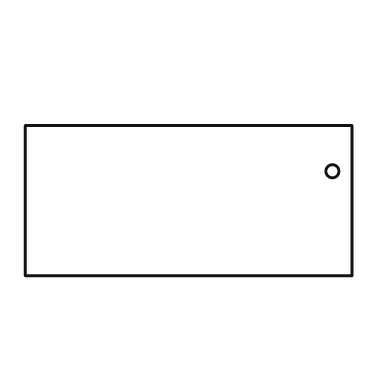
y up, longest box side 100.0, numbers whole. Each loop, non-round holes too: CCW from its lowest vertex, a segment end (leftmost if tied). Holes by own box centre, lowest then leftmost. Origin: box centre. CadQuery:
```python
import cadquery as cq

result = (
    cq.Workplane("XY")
    .moveTo(-50.0, -23.0)
    .lineTo(50.0, -23.0)
    .lineTo(50.0, 23.0)
    .lineTo(-50.0, 23.0)
    .close()
    .moveTo(44.0, 9.0)
    .circle(2.0)
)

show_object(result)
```